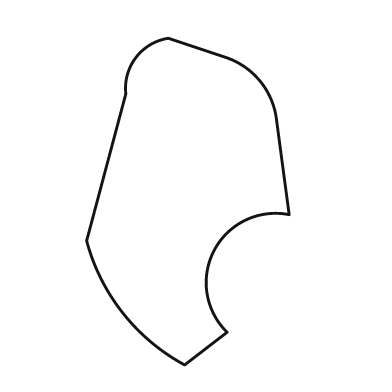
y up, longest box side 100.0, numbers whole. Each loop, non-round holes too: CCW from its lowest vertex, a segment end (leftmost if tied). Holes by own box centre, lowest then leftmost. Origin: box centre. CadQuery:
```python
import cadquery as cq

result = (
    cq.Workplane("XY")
    .moveTo(-1.0, -50.0)
    .lineTo(12.0, -40.0)
    .threePointArc((8.0, -15.0), (31.0, -4.0))
    .lineTo(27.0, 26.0)
    .threePointArc((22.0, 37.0), (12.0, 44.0))
    .lineTo(-6.0, 50.0)
    .threePointArc((-16.0, 44.0), (-19.0, 33.0))
    .lineTo(-31.0, -12.0)
    .threePointArc((-20.0, -34.0), (-1.0, -50.0))
    .close()
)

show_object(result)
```